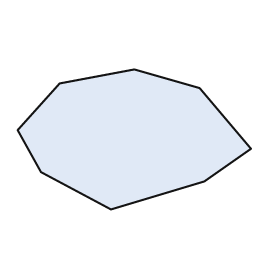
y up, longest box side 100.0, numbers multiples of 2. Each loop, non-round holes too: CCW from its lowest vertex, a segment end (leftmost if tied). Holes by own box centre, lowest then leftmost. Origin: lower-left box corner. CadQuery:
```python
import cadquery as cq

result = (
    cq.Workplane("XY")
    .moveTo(40.0, 0.0)
    .lineTo(80.0, 12.0)
    .lineTo(100.0, 26.0)
    .lineTo(78.0, 52.0)
    .lineTo(50.0, 60.0)
    .lineTo(18.0, 54.0)
    .lineTo(0.0, 34.0)
    .lineTo(10.0, 16.0)
    .close()
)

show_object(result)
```